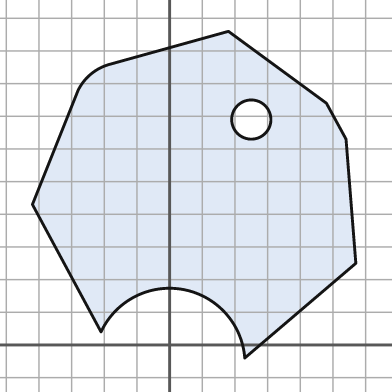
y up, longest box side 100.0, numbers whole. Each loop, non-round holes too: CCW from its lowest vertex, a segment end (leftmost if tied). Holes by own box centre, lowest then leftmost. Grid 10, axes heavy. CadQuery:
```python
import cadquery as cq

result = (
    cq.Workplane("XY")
    .moveTo(23.0, -4.0)
    .lineTo(57.0, 25.0)
    .lineTo(54.0, 63.0)
    .lineTo(48.0, 74.0)
    .lineTo(18.0, 96.0)
    .lineTo(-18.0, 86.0)
    .threePointArc((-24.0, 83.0), (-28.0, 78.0))
    .lineTo(-42.0, 43.0)
    .lineTo(-21.0, 4.0)
    .threePointArc((4.0, 17.0), (23.0, -4.0))
    .close()
    .moveTo(25.0, 69.0)
    .circle(6.0)
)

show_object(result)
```